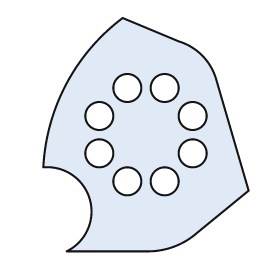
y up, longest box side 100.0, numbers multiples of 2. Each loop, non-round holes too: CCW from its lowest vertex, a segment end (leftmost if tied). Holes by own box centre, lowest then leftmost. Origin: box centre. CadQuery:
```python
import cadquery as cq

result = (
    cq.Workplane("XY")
    .moveTo(-34.0, -50.0)
    .lineTo(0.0, -50.0)
    .threePointArc((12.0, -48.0), (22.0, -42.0))
    .lineTo(44.0, -24.0)
    .lineTo(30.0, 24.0)
    .threePointArc((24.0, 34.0), (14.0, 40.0))
    .lineTo(-10.0, 50.0)
    .threePointArc((-34.0, 22.0), (-44.0, -14.0))
    .threePointArc((-24.0, -28.0), (-34.0, -50.0))
    .close()
    .moveTo(-8.0, -20.0)
    .circle(6.0)
    .moveTo(8.0, -20.0)
    .circle(6.0)
    .moveTo(-20.0, -8.0)
    .circle(6.0)
    .moveTo(20.0, -8.0)
    .circle(6.0)
    .moveTo(-20.0, 8.0)
    .circle(6.0)
    .moveTo(20.0, 8.0)
    .circle(6.0)
    .moveTo(-8.0, 20.0)
    .circle(6.0)
    .moveTo(8.0, 20.0)
    .circle(6.0)
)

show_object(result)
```